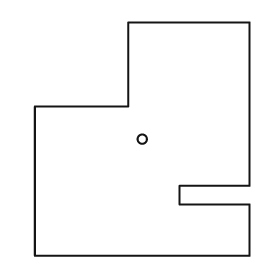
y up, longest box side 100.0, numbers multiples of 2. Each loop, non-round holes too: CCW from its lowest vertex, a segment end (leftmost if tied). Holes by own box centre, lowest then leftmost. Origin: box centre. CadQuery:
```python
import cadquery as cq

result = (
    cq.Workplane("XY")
    .moveTo(-46.0, -50.0)
    .lineTo(46.0, -50.0)
    .lineTo(46.0, -28.0)
    .lineTo(16.0, -28.0)
    .lineTo(16.0, -20.0)
    .lineTo(46.0, -20.0)
    .lineTo(46.0, 50.0)
    .lineTo(-6.0, 50.0)
    .lineTo(-6.0, 14.0)
    .lineTo(-46.0, 14.0)
    .close()
    .moveTo(0.0, 0.0)
    .circle(2.0)
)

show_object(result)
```